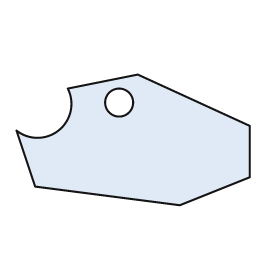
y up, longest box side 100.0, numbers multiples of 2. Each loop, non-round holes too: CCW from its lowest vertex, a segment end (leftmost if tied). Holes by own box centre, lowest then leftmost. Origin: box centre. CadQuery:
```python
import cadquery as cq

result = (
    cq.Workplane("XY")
    .moveTo(20.0, -28.0)
    .lineTo(50.0, -16.0)
    .lineTo(50.0, 6.0)
    .lineTo(2.0, 28.0)
    .lineTo(-28.0, 22.0)
    .threePointArc((-32.0, 4.0), (-50.0, 4.0))
    .lineTo(-42.0, -20.0)
    .close()
    .moveTo(-6.0, 16.0)
    .circle(6.0)
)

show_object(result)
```